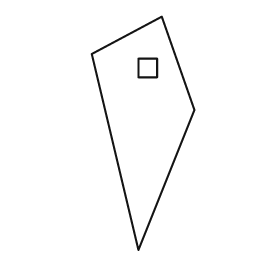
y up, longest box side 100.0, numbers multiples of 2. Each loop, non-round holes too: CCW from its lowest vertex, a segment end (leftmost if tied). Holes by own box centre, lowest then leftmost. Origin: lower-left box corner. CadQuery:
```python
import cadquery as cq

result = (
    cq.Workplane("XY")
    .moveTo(20.0, 0.0)
    .lineTo(44.0, 60.0)
    .lineTo(30.0, 100.0)
    .lineTo(0.0, 84.0)
    .close()
    .moveTo(20.0, 74.0)
    .lineTo(28.0, 74.0)
    .lineTo(28.0, 82.0)
    .lineTo(20.0, 82.0)
    .close()
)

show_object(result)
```